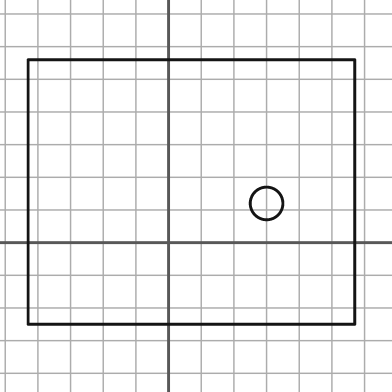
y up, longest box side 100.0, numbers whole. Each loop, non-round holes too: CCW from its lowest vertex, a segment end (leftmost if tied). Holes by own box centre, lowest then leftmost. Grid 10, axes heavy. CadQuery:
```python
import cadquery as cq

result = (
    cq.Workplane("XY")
    .moveTo(-43.0, -25.0)
    .lineTo(57.0, -25.0)
    .lineTo(57.0, 56.0)
    .lineTo(-43.0, 56.0)
    .close()
    .moveTo(30.0, 12.0)
    .circle(5.0)
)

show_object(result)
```